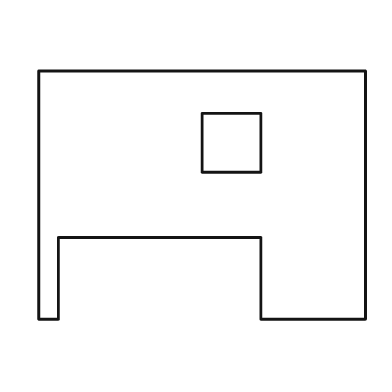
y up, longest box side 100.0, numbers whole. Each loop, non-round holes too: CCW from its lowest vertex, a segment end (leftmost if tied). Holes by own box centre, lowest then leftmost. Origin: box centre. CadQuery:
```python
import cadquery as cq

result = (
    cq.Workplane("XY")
    .moveTo(-50.0, -38.0)
    .lineTo(-44.0, -38.0)
    .lineTo(-44.0, -13.0)
    .lineTo(18.0, -13.0)
    .lineTo(18.0, -38.0)
    .lineTo(50.0, -38.0)
    .lineTo(50.0, 38.0)
    .lineTo(-50.0, 38.0)
    .close()
    .moveTo(0.0, 7.0)
    .lineTo(18.0, 7.0)
    .lineTo(18.0, 25.0)
    .lineTo(0.0, 25.0)
    .close()
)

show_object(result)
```